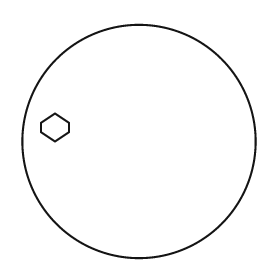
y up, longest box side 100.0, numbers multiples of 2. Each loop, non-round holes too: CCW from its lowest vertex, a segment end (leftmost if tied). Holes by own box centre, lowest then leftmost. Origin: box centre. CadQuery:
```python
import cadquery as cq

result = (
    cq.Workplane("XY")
    .moveTo(0.0, 0.0)
    .circle(50.0)
    .moveTo(-36.0, 0.0)
    .lineTo(-30.0, 4.0)
    .lineTo(-30.0, 8.0)
    .lineTo(-36.0, 12.0)
    .lineTo(-42.0, 8.0)
    .lineTo(-42.0, 4.0)
    .close()
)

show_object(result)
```